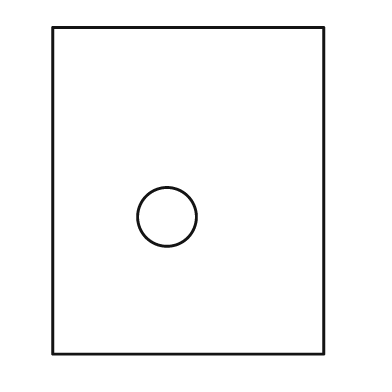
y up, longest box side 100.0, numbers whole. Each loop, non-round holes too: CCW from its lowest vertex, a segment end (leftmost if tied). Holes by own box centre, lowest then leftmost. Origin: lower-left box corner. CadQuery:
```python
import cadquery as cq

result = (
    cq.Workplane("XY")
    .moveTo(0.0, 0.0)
    .lineTo(83.0, 0.0)
    .lineTo(83.0, 100.0)
    .lineTo(0.0, 100.0)
    .close()
    .moveTo(35.0, 42.0)
    .circle(9.0)
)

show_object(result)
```